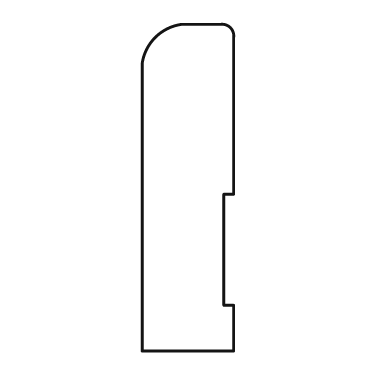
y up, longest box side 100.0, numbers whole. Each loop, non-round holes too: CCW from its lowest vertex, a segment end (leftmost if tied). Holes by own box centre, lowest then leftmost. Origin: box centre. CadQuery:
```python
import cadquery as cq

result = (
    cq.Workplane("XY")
    .moveTo(-14.0, -50.0)
    .lineTo(14.0, -50.0)
    .lineTo(14.0, -36.0)
    .lineTo(11.0, -36.0)
    .lineTo(11.0, -2.0)
    .lineTo(14.0, -2.0)
    .lineTo(14.0, 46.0)
    .threePointArc((13.0, 49.0), (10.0, 50.0))
    .lineTo(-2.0, 50.0)
    .threePointArc((-10.0, 46.0), (-14.0, 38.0))
    .close()
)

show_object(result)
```